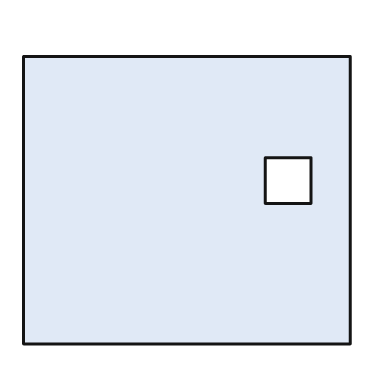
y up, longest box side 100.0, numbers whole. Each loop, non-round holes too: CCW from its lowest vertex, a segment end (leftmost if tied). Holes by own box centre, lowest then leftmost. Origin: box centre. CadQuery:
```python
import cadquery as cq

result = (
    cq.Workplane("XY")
    .moveTo(-50.0, -44.0)
    .lineTo(50.0, -44.0)
    .lineTo(50.0, 44.0)
    .lineTo(-50.0, 44.0)
    .close()
    .moveTo(24.0, -1.0)
    .lineTo(38.0, -1.0)
    .lineTo(38.0, 13.0)
    .lineTo(24.0, 13.0)
    .close()
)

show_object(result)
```